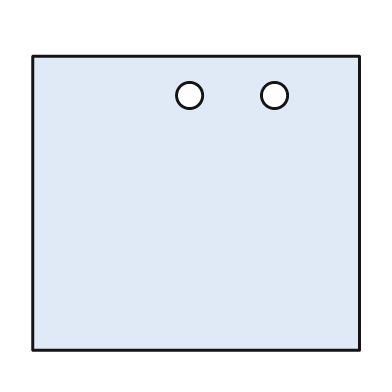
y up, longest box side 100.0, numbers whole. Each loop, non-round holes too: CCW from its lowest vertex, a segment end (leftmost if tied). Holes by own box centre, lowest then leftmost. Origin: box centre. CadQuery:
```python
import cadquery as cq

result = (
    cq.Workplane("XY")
    .moveTo(-50.0, -45.0)
    .lineTo(50.0, -45.0)
    .lineTo(50.0, 45.0)
    .lineTo(-50.0, 45.0)
    .close()
    .moveTo(-2.0, 33.0)
    .circle(4.0)
    .moveTo(24.0, 33.0)
    .circle(4.0)
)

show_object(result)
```